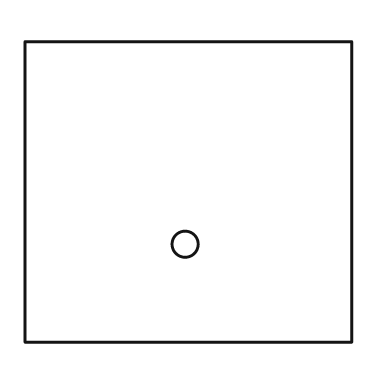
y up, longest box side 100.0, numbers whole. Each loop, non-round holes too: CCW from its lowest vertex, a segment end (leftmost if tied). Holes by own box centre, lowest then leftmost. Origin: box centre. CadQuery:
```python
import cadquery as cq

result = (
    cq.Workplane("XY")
    .moveTo(-50.0, -46.0)
    .lineTo(50.0, -46.0)
    .lineTo(50.0, 46.0)
    .lineTo(-50.0, 46.0)
    .close()
    .moveTo(-1.0, -16.0)
    .circle(4.0)
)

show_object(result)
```